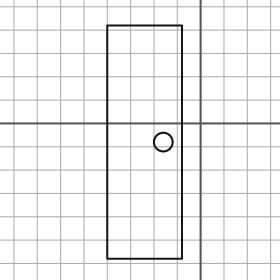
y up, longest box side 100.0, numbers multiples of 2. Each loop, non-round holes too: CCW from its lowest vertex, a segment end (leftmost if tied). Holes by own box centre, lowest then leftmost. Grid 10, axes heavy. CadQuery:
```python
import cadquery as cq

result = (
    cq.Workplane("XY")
    .moveTo(-40.0, -58.0)
    .lineTo(-8.0, -58.0)
    .lineTo(-8.0, 42.0)
    .lineTo(-40.0, 42.0)
    .close()
    .moveTo(-16.0, -8.0)
    .circle(4.0)
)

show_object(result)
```